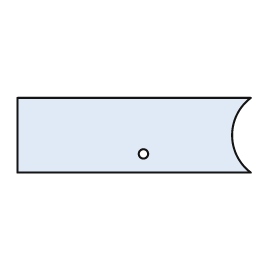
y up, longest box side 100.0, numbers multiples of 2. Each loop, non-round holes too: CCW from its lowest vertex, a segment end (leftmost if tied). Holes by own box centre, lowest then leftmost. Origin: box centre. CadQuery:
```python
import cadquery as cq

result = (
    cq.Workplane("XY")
    .moveTo(-50.0, -16.0)
    .lineTo(50.0, -16.0)
    .threePointArc((42.0, 0.0), (50.0, 16.0))
    .lineTo(-50.0, 16.0)
    .close()
    .moveTo(4.0, -8.0)
    .circle(2.0)
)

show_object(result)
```